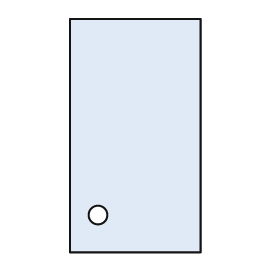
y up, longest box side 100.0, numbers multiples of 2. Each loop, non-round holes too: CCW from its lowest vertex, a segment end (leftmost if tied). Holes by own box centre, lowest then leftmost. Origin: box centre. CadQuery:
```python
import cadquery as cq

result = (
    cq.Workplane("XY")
    .moveTo(-28.0, -50.0)
    .lineTo(28.0, -50.0)
    .lineTo(28.0, 50.0)
    .lineTo(-28.0, 50.0)
    .close()
    .moveTo(-16.0, -34.0)
    .circle(4.0)
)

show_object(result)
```